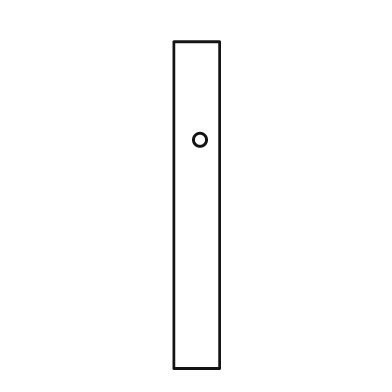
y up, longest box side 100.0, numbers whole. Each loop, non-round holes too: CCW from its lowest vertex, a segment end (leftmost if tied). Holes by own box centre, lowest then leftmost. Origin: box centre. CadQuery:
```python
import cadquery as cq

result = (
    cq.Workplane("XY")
    .moveTo(-7.0, -50.0)
    .lineTo(7.0, -50.0)
    .lineTo(7.0, 50.0)
    .lineTo(-7.0, 50.0)
    .close()
    .moveTo(1.0, 20.0)
    .circle(2.0)
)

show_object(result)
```